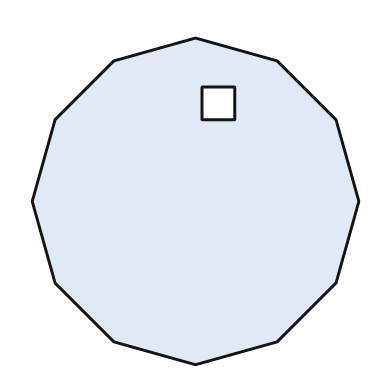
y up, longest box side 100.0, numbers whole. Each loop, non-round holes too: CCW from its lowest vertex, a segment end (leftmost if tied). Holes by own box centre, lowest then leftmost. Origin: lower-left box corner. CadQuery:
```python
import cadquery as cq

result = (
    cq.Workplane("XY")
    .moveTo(50.0, 0.0)
    .lineTo(75.0, 7.0)
    .lineTo(93.0, 25.0)
    .lineTo(100.0, 50.0)
    .lineTo(93.0, 75.0)
    .lineTo(75.0, 93.0)
    .lineTo(50.0, 100.0)
    .lineTo(25.0, 93.0)
    .lineTo(7.0, 75.0)
    .lineTo(0.0, 50.0)
    .lineTo(7.0, 25.0)
    .lineTo(25.0, 7.0)
    .close()
    .moveTo(52.0, 75.0)
    .lineTo(62.0, 75.0)
    .lineTo(62.0, 85.0)
    .lineTo(52.0, 85.0)
    .close()
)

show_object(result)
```